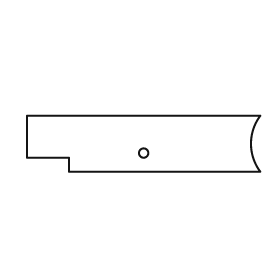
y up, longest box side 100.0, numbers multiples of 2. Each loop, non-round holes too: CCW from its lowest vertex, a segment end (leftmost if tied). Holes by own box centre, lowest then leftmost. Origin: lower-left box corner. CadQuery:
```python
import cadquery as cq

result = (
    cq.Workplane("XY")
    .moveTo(18.0, 0.0)
    .lineTo(100.0, 0.0)
    .threePointArc((96.0, 12.0), (100.0, 24.0))
    .lineTo(0.0, 24.0)
    .lineTo(0.0, 6.0)
    .lineTo(18.0, 6.0)
    .close()
    .moveTo(50.0, 8.0)
    .circle(2.0)
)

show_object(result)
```